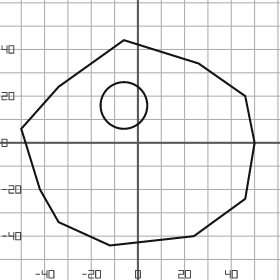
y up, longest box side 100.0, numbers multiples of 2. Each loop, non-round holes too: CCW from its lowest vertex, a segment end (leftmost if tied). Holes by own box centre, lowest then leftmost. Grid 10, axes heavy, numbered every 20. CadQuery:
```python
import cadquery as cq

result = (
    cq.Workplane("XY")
    .moveTo(-12.0, -44.0)
    .lineTo(24.0, -40.0)
    .lineTo(46.0, -24.0)
    .lineTo(50.0, 0.0)
    .lineTo(46.0, 20.0)
    .lineTo(26.0, 34.0)
    .lineTo(-6.0, 44.0)
    .lineTo(-34.0, 24.0)
    .lineTo(-50.0, 6.0)
    .lineTo(-42.0, -20.0)
    .lineTo(-34.0, -34.0)
    .close()
    .moveTo(-6.0, 16.0)
    .circle(10.0)
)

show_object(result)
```